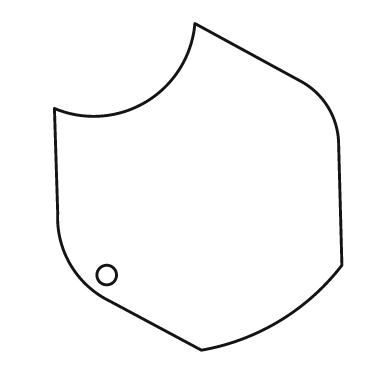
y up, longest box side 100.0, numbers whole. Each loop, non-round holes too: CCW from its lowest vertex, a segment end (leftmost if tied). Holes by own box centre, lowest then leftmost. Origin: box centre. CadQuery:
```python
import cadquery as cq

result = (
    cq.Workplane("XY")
    .moveTo(1.0, -50.0)
    .threePointArc((25.0, -41.0), (44.0, -24.0))
    .lineTo(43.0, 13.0)
    .threePointArc((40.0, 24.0), (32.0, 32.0))
    .lineTo(-1.0, 50.0)
    .threePointArc((-16.0, 26.0), (-44.0, 24.0))
    .lineTo(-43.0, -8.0)
    .threePointArc((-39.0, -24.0), (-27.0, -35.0))
    .close()
    .moveTo(-28.0, -27.0)
    .circle(3.0)
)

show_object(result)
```